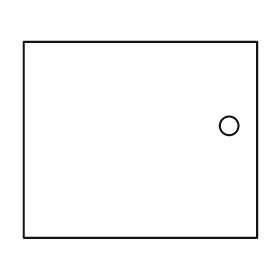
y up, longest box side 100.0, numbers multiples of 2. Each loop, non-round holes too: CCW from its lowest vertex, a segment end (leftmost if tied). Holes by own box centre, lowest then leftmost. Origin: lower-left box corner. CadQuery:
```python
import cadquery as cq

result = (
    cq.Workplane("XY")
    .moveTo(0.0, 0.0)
    .lineTo(100.0, 0.0)
    .lineTo(100.0, 84.0)
    .lineTo(0.0, 84.0)
    .close()
    .moveTo(88.0, 48.0)
    .circle(4.0)
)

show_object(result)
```